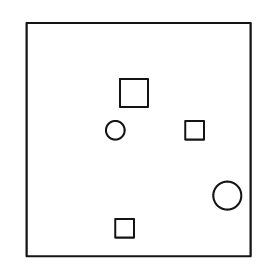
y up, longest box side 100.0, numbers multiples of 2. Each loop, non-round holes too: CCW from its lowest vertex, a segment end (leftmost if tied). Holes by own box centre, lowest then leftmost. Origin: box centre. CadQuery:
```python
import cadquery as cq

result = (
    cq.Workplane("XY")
    .moveTo(-48.0, -50.0)
    .lineTo(48.0, -50.0)
    .lineTo(48.0, 50.0)
    .lineTo(-48.0, 50.0)
    .close()
    .moveTo(-10.0, -42.0)
    .lineTo(-2.0, -42.0)
    .lineTo(-2.0, -34.0)
    .lineTo(-10.0, -34.0)
    .close()
    .moveTo(38.0, -24.0)
    .circle(6.0)
    .moveTo(-10.0, 4.0)
    .circle(4.0)
    .moveTo(20.0, 0.0)
    .lineTo(28.0, 0.0)
    .lineTo(28.0, 8.0)
    .lineTo(20.0, 8.0)
    .close()
    .moveTo(-8.0, 14.0)
    .lineTo(4.0, 14.0)
    .lineTo(4.0, 26.0)
    .lineTo(-8.0, 26.0)
    .close()
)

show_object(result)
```